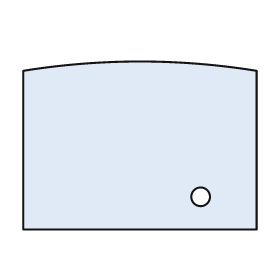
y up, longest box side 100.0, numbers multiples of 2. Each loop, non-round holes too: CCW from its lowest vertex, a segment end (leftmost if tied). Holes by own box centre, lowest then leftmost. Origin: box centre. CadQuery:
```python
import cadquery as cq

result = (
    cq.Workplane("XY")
    .moveTo(-50.0, -36.0)
    .lineTo(50.0, -36.0)
    .lineTo(50.0, 32.0)
    .threePointArc((0.0, 36.0), (-50.0, 32.0))
    .close()
    .moveTo(26.0, -22.0)
    .circle(4.0)
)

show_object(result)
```